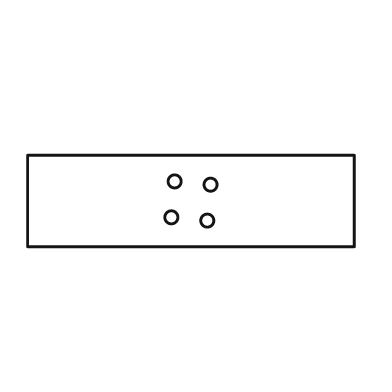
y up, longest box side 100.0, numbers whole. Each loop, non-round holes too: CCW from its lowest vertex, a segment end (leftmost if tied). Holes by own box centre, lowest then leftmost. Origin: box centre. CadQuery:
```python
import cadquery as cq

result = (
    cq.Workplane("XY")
    .moveTo(-50.0, -14.0)
    .lineTo(50.0, -14.0)
    .lineTo(50.0, 14.0)
    .lineTo(-50.0, 14.0)
    .close()
    .moveTo(5.0, -6.0)
    .circle(2.0)
    .moveTo(-6.0, -5.0)
    .circle(2.0)
    .moveTo(6.0, 5.0)
    .circle(2.0)
    .moveTo(-5.0, 6.0)
    .circle(2.0)
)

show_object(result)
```